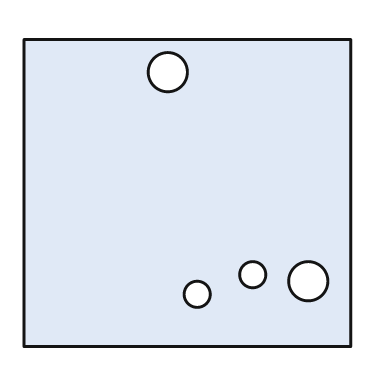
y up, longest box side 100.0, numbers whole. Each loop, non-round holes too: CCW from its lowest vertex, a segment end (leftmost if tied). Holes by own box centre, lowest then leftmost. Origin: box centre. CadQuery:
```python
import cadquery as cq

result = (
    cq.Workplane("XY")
    .moveTo(-50.0, -47.0)
    .lineTo(50.0, -47.0)
    .lineTo(50.0, 47.0)
    .lineTo(-50.0, 47.0)
    .close()
    .moveTo(3.0, -31.0)
    .circle(4.0)
    .moveTo(37.0, -27.0)
    .circle(6.0)
    .moveTo(20.0, -25.0)
    .circle(4.0)
    .moveTo(-6.0, 37.0)
    .circle(6.0)
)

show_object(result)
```